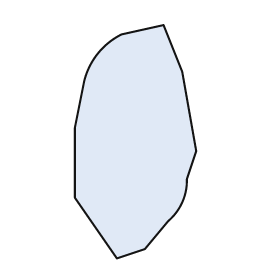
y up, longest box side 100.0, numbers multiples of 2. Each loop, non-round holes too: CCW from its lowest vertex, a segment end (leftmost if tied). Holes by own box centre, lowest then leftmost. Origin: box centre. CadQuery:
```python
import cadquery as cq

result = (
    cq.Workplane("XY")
    .moveTo(-8.0, -50.0)
    .lineTo(4.0, -46.0)
    .lineTo(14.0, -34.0)
    .threePointArc((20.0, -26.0), (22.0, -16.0))
    .lineTo(26.0, -4.0)
    .lineTo(20.0, 30.0)
    .lineTo(12.0, 50.0)
    .lineTo(-6.0, 46.0)
    .threePointArc((-16.0, 38.0), (-22.0, 26.0))
    .lineTo(-26.0, 6.0)
    .lineTo(-26.0, -24.0)
    .close()
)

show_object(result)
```